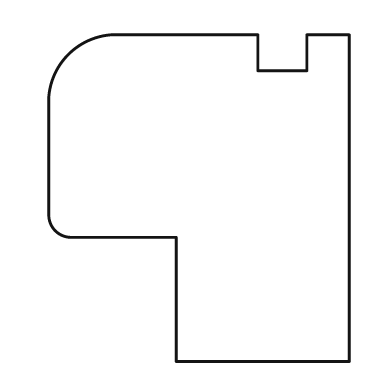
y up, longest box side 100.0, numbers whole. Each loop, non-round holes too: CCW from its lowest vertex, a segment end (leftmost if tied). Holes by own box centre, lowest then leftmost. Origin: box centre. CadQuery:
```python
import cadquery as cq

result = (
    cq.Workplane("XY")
    .moveTo(-7.0, -50.0)
    .lineTo(46.0, -50.0)
    .lineTo(46.0, 50.0)
    .lineTo(33.0, 50.0)
    .lineTo(33.0, 39.0)
    .lineTo(18.0, 39.0)
    .lineTo(18.0, 50.0)
    .lineTo(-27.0, 50.0)
    .threePointArc((-40.0, 44.0), (-46.0, 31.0))
    .lineTo(-46.0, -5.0)
    .threePointArc((-44.0, -10.0), (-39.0, -12.0))
    .lineTo(-7.0, -12.0)
    .close()
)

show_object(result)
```